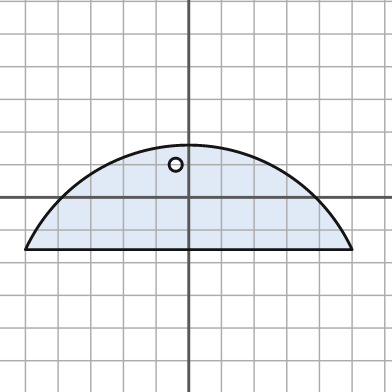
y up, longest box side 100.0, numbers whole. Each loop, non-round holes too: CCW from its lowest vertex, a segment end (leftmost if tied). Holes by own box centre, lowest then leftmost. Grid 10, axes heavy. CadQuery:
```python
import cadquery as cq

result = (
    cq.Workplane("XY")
    .moveTo(-50.0, -16.0)
    .lineTo(50.0, -16.0)
    .threePointArc((0.0, 16.0), (-50.0, -16.0))
    .close()
    .moveTo(-4.0, 10.0)
    .circle(2.0)
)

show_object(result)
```